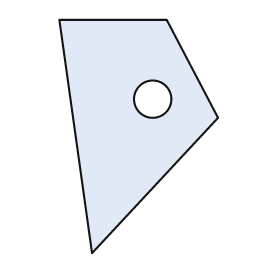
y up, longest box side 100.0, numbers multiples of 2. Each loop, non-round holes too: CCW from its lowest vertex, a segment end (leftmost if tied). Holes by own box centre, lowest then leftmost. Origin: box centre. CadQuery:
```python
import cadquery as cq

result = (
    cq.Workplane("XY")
    .moveTo(-20.0, -50.0)
    .lineTo(34.0, 8.0)
    .lineTo(12.0, 50.0)
    .lineTo(-34.0, 50.0)
    .close()
    .moveTo(6.0, 16.0)
    .circle(8.0)
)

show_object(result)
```